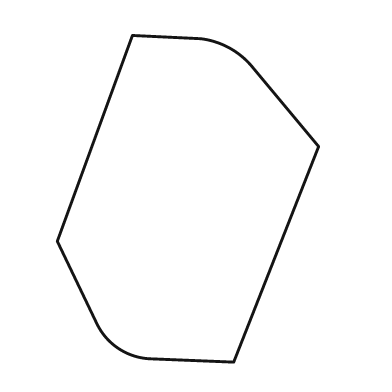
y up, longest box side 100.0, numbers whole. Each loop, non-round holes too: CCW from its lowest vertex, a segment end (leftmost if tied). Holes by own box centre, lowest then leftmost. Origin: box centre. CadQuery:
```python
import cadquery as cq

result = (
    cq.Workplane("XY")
    .moveTo(14.0, -50.0)
    .lineTo(40.0, 16.0)
    .lineTo(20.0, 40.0)
    .threePointArc((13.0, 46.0), (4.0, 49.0))
    .lineTo(-17.0, 50.0)
    .lineTo(-40.0, -13.0)
    .lineTo(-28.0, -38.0)
    .threePointArc((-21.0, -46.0), (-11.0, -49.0))
    .close()
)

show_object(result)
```